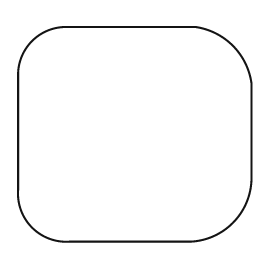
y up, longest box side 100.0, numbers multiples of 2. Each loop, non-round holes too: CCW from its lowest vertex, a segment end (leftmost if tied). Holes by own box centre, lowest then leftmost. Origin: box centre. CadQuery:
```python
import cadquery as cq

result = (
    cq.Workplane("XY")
    .moveTo(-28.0, -46.0)
    .lineTo(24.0, -46.0)
    .threePointArc((42.0, -38.0), (50.0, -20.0))
    .lineTo(50.0, 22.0)
    .threePointArc((42.0, 38.0), (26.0, 46.0))
    .lineTo(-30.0, 46.0)
    .threePointArc((-44.0, 40.0), (-50.0, 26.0))
    .lineTo(-50.0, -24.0)
    .threePointArc((-44.0, -40.0), (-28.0, -46.0))
    .close()
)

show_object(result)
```